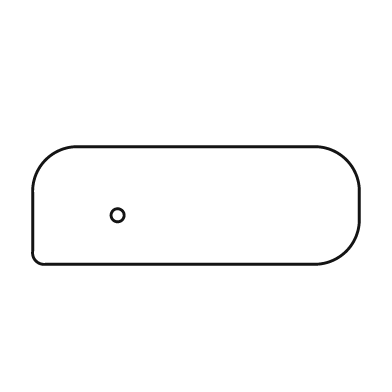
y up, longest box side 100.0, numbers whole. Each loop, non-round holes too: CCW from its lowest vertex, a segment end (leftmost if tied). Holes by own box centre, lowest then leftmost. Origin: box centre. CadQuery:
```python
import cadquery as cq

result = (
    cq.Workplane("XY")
    .moveTo(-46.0, -18.0)
    .lineTo(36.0, -18.0)
    .threePointArc((46.0, -14.0), (50.0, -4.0))
    .lineTo(50.0, 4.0)
    .threePointArc((46.0, 14.0), (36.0, 18.0))
    .lineTo(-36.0, 18.0)
    .threePointArc((-46.0, 14.0), (-50.0, 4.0))
    .lineTo(-50.0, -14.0)
    .threePointArc((-49.0, -17.0), (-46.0, -18.0))
    .close()
    .moveTo(-24.0, -3.0)
    .circle(2.0)
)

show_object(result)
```